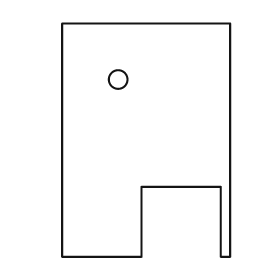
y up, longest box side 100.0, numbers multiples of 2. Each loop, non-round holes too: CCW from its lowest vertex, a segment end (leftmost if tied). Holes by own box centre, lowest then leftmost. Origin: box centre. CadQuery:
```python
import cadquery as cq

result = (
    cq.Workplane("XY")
    .moveTo(-36.0, -50.0)
    .lineTo(-2.0, -50.0)
    .lineTo(-2.0, -20.0)
    .lineTo(32.0, -20.0)
    .lineTo(32.0, -50.0)
    .lineTo(36.0, -50.0)
    .lineTo(36.0, 50.0)
    .lineTo(-36.0, 50.0)
    .close()
    .moveTo(-12.0, 26.0)
    .circle(4.0)
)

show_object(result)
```